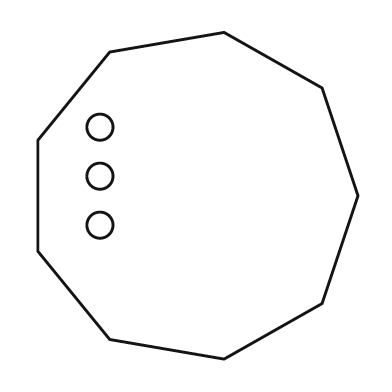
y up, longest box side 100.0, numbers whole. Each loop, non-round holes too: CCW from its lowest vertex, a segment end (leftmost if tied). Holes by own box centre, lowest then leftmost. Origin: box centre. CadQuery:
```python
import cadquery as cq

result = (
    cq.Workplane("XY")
    .moveTo(8.0, -50.0)
    .lineTo(38.0, -33.0)
    .lineTo(49.0, 0.0)
    .lineTo(38.0, 33.0)
    .lineTo(8.0, 50.0)
    .lineTo(-27.0, 44.0)
    .lineTo(-49.0, 17.0)
    .lineTo(-49.0, -17.0)
    .lineTo(-27.0, -44.0)
    .close()
    .moveTo(-30.0, -9.0)
    .circle(4.0)
    .moveTo(-30.0, 6.0)
    .circle(4.0)
    .moveTo(-30.0, 21.0)
    .circle(4.0)
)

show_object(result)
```